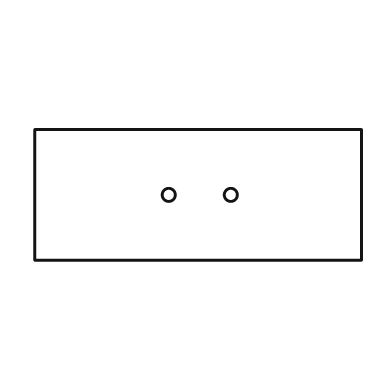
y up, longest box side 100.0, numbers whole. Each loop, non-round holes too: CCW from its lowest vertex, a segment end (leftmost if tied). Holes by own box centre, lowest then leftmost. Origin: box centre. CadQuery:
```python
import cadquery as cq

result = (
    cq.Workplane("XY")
    .moveTo(-50.0, -20.0)
    .lineTo(50.0, -20.0)
    .lineTo(50.0, 20.0)
    .lineTo(-50.0, 20.0)
    .close()
    .moveTo(-9.0, 0.0)
    .circle(2.0)
    .moveTo(10.0, 0.0)
    .circle(2.0)
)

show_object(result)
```